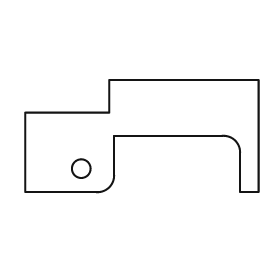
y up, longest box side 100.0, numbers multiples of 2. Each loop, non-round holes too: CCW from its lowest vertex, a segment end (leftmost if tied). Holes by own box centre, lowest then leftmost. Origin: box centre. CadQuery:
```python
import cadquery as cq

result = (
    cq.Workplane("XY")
    .moveTo(-50.0, -24.0)
    .lineTo(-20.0, -24.0)
    .threePointArc((-14.0, -22.0), (-12.0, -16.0))
    .lineTo(-12.0, 0.0)
    .lineTo(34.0, 0.0)
    .threePointArc((40.0, -2.0), (42.0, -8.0))
    .lineTo(42.0, -24.0)
    .lineTo(50.0, -24.0)
    .lineTo(50.0, 24.0)
    .lineTo(-14.0, 24.0)
    .lineTo(-14.0, 10.0)
    .lineTo(-50.0, 10.0)
    .close()
    .moveTo(-26.0, -14.0)
    .circle(4.0)
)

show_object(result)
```